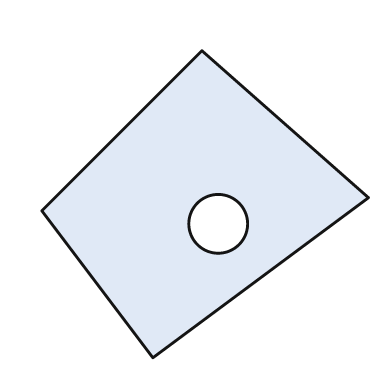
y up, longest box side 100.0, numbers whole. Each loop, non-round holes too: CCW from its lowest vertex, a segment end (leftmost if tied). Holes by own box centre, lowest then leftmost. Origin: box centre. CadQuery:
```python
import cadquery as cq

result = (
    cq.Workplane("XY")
    .moveTo(-16.0, -47.0)
    .lineTo(50.0, 2.0)
    .lineTo(-1.0, 47.0)
    .lineTo(-50.0, -2.0)
    .close()
    .moveTo(4.0, -6.0)
    .circle(9.0)
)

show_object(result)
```